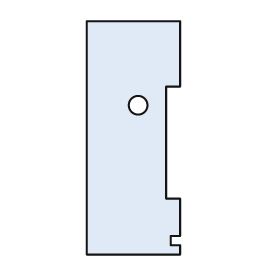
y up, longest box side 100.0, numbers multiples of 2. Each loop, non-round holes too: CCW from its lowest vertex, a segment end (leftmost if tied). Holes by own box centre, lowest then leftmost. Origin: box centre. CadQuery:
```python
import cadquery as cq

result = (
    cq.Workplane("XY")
    .moveTo(-20.0, -50.0)
    .lineTo(20.0, -50.0)
    .lineTo(20.0, -46.0)
    .lineTo(16.0, -46.0)
    .lineTo(16.0, -42.0)
    .lineTo(20.0, -42.0)
    .lineTo(20.0, -26.0)
    .lineTo(14.0, -26.0)
    .lineTo(14.0, 22.0)
    .lineTo(20.0, 22.0)
    .lineTo(20.0, 50.0)
    .lineTo(-20.0, 50.0)
    .close()
    .moveTo(2.0, 14.0)
    .circle(4.0)
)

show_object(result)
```